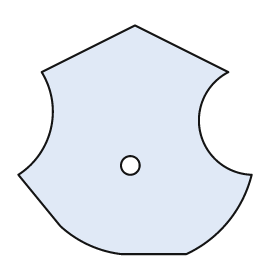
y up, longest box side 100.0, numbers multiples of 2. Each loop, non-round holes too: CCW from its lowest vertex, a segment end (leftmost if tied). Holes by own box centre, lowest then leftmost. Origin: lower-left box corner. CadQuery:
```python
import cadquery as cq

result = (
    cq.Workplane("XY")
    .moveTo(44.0, 0.0)
    .lineTo(72.0, 0.0)
    .threePointArc((90.0, 14.0), (100.0, 34.0))
    .threePointArc((78.0, 52.0), (90.0, 78.0))
    .lineTo(50.0, 98.0)
    .lineTo(10.0, 78.0)
    .threePointArc((14.0, 54.0), (0.0, 34.0))
    .lineTo(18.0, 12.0)
    .threePointArc((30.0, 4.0), (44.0, 0.0))
    .close()
    .moveTo(48.0, 38.0)
    .circle(4.0)
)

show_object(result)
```